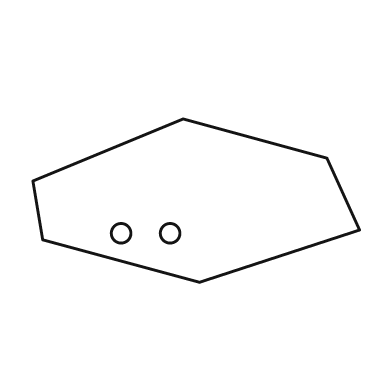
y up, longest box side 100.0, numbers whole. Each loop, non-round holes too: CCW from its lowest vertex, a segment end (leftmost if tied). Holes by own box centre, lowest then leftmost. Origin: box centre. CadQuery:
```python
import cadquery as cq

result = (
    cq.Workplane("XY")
    .moveTo(1.0, -25.0)
    .lineTo(50.0, -9.0)
    .lineTo(40.0, 13.0)
    .lineTo(-4.0, 25.0)
    .lineTo(-50.0, 6.0)
    .lineTo(-47.0, -12.0)
    .close()
    .moveTo(-23.0, -10.0)
    .circle(3.0)
    .moveTo(-8.0, -10.0)
    .circle(3.0)
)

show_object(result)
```